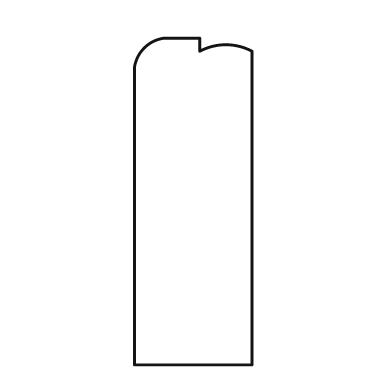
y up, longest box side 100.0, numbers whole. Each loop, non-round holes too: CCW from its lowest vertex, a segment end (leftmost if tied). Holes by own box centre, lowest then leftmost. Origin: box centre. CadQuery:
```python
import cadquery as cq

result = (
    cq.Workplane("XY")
    .moveTo(-18.0, -50.0)
    .lineTo(18.0, -50.0)
    .lineTo(18.0, 46.0)
    .threePointArc((10.0, 48.0), (2.0, 46.0))
    .lineTo(2.0, 50.0)
    .lineTo(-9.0, 50.0)
    .threePointArc((-15.0, 47.0), (-18.0, 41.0))
    .close()
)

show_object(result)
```